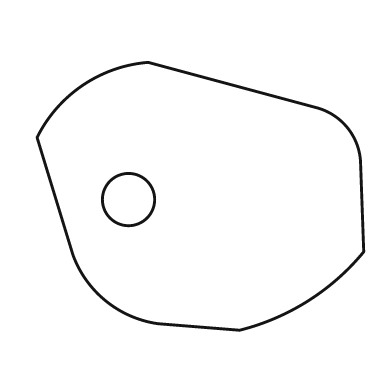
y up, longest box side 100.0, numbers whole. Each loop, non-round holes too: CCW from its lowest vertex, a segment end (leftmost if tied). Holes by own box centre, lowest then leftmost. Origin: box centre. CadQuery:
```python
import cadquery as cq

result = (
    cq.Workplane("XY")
    .moveTo(12.0, -41.0)
    .threePointArc((33.0, -32.0), (50.0, -17.0))
    .lineTo(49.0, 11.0)
    .threePointArc((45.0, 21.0), (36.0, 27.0))
    .lineTo(-16.0, 41.0)
    .threePointArc((-36.0, 34.0), (-50.0, 18.0))
    .lineTo(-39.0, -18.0)
    .threePointArc((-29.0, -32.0), (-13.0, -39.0))
    .close()
    .moveTo(-22.0, -1.0)
    .circle(8.0)
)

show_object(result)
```